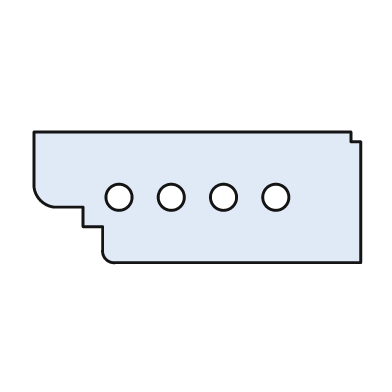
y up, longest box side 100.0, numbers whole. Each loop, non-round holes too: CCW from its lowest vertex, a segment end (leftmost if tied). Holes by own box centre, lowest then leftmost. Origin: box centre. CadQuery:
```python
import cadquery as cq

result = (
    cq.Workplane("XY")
    .moveTo(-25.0, -20.0)
    .lineTo(50.0, -20.0)
    .lineTo(50.0, 17.0)
    .lineTo(47.0, 17.0)
    .lineTo(47.0, 20.0)
    .lineTo(-50.0, 20.0)
    .lineTo(-50.0, 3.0)
    .threePointArc((-48.0, -1.0), (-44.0, -3.0))
    .lineTo(-35.0, -3.0)
    .lineTo(-35.0, -9.0)
    .lineTo(-29.0, -9.0)
    .lineTo(-29.0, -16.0)
    .threePointArc((-28.0, -19.0), (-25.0, -20.0))
    .close()
    .moveTo(-24.0, 0.0)
    .circle(4.0)
    .moveTo(-8.0, 0.0)
    .circle(4.0)
    .moveTo(8.0, 0.0)
    .circle(4.0)
    .moveTo(24.0, 0.0)
    .circle(4.0)
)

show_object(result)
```